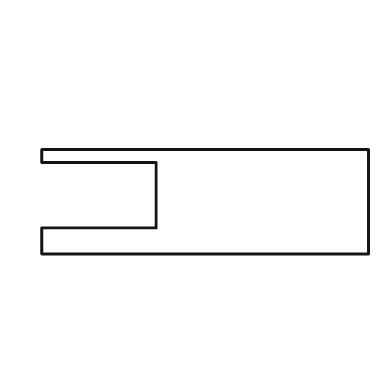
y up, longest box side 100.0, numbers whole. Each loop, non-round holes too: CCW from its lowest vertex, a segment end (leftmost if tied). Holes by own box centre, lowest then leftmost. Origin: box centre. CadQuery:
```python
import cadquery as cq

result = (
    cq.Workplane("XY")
    .moveTo(-50.0, -16.0)
    .lineTo(50.0, -16.0)
    .lineTo(50.0, 16.0)
    .lineTo(-50.0, 16.0)
    .lineTo(-50.0, 12.0)
    .lineTo(-15.0, 12.0)
    .lineTo(-15.0, -8.0)
    .lineTo(-50.0, -8.0)
    .close()
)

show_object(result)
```